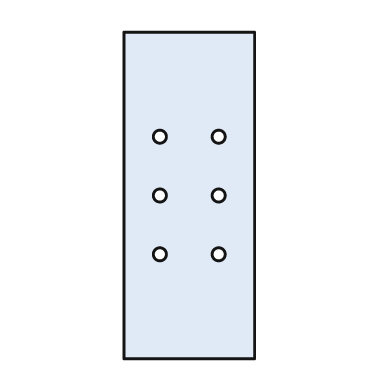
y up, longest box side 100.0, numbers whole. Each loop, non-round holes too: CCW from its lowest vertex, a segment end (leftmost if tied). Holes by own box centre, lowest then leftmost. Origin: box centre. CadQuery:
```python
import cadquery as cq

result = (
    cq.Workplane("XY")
    .moveTo(-20.0, -50.0)
    .lineTo(20.0, -50.0)
    .lineTo(20.0, 50.0)
    .lineTo(-20.0, 50.0)
    .close()
    .moveTo(-9.0, -18.0)
    .circle(2.0)
    .moveTo(9.0, -18.0)
    .circle(2.0)
    .moveTo(-9.0, 0.0)
    .circle(2.0)
    .moveTo(9.0, 0.0)
    .circle(2.0)
    .moveTo(-9.0, 18.0)
    .circle(2.0)
    .moveTo(9.0, 18.0)
    .circle(2.0)
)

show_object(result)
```